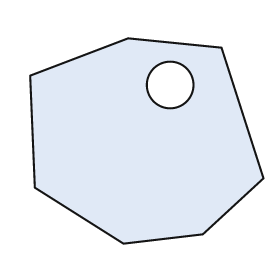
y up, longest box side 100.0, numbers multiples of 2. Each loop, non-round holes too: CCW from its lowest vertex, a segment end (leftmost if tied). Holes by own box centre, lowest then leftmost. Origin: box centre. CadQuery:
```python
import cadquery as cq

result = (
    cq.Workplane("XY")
    .moveTo(-10.0, -44.0)
    .lineTo(24.0, -40.0)
    .lineTo(50.0, -16.0)
    .lineTo(32.0, 40.0)
    .lineTo(-8.0, 44.0)
    .lineTo(-50.0, 28.0)
    .lineTo(-48.0, -20.0)
    .close()
    .moveTo(10.0, 24.0)
    .circle(10.0)
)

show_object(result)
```